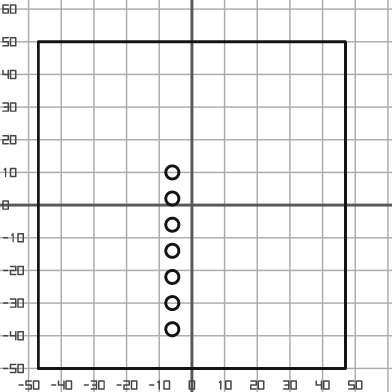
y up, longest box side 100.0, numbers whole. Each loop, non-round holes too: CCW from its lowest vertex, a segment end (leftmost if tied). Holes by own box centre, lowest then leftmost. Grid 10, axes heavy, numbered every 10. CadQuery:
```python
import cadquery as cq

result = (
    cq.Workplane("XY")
    .moveTo(-47.0, -50.0)
    .lineTo(47.0, -50.0)
    .lineTo(47.0, 50.0)
    .lineTo(-47.0, 50.0)
    .close()
    .moveTo(-6.0, -38.0)
    .circle(2.0)
    .moveTo(-6.0, -30.0)
    .circle(2.0)
    .moveTo(-6.0, -22.0)
    .circle(2.0)
    .moveTo(-6.0, -14.0)
    .circle(2.0)
    .moveTo(-6.0, -6.0)
    .circle(2.0)
    .moveTo(-6.0, 2.0)
    .circle(2.0)
    .moveTo(-6.0, 10.0)
    .circle(2.0)
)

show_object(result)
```